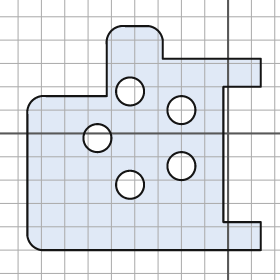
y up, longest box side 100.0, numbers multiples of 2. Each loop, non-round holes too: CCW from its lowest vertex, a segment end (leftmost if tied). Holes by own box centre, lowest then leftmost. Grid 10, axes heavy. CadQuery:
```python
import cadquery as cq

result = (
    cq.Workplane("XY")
    .moveTo(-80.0, -50.0)
    .lineTo(14.0, -50.0)
    .lineTo(14.0, -38.0)
    .lineTo(-2.0, -38.0)
    .lineTo(-2.0, 20.0)
    .lineTo(14.0, 20.0)
    .lineTo(14.0, 32.0)
    .lineTo(-28.0, 32.0)
    .lineTo(-28.0, 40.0)
    .threePointArc((-30.0, 44.0), (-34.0, 46.0))
    .lineTo(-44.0, 46.0)
    .threePointArc((-50.0, 44.0), (-52.0, 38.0))
    .lineTo(-52.0, 16.0)
    .lineTo(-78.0, 16.0)
    .threePointArc((-84.0, 14.0), (-86.0, 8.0))
    .lineTo(-86.0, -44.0)
    .threePointArc((-84.0, -48.0), (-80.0, -50.0))
    .close()
    .moveTo(-42.0, -22.0)
    .circle(6.0)
    .moveTo(-20.0, -14.0)
    .circle(6.0)
    .moveTo(-56.0, -2.0)
    .circle(6.0)
    .moveTo(-20.0, 10.0)
    .circle(6.0)
    .moveTo(-42.0, 18.0)
    .circle(6.0)
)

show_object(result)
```